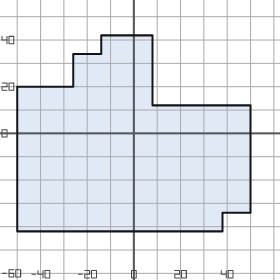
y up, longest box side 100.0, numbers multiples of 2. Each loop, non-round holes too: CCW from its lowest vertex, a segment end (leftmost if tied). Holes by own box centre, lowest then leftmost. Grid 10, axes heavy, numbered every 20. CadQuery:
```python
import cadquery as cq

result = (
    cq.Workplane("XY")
    .moveTo(-50.0, -42.0)
    .lineTo(38.0, -42.0)
    .lineTo(38.0, -34.0)
    .lineTo(50.0, -34.0)
    .lineTo(50.0, 12.0)
    .lineTo(8.0, 12.0)
    .lineTo(8.0, 42.0)
    .lineTo(-14.0, 42.0)
    .lineTo(-14.0, 34.0)
    .lineTo(-26.0, 34.0)
    .lineTo(-26.0, 20.0)
    .lineTo(-50.0, 20.0)
    .close()
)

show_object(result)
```